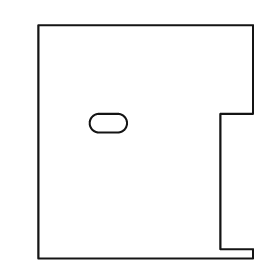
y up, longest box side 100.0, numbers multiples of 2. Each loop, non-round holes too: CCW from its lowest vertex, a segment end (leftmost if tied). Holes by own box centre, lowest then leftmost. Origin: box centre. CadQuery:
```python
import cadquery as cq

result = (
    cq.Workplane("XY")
    .moveTo(-46.0, -50.0)
    .lineTo(46.0, -50.0)
    .lineTo(46.0, -46.0)
    .lineTo(32.0, -46.0)
    .lineTo(32.0, 12.0)
    .lineTo(46.0, 12.0)
    .lineTo(46.0, 50.0)
    .lineTo(-46.0, 50.0)
    .close()
    .moveTo(-20.0, 4.0)
    .lineTo(-12.0, 4.0)
    .threePointArc((-8.0, 8.0), (-12.0, 12.0))
    .lineTo(-20.0, 12.0)
    .threePointArc((-24.0, 8.0), (-20.0, 4.0))
    .close()
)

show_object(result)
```